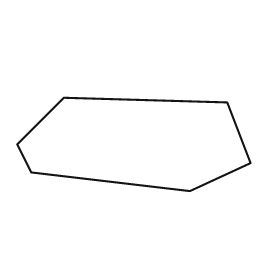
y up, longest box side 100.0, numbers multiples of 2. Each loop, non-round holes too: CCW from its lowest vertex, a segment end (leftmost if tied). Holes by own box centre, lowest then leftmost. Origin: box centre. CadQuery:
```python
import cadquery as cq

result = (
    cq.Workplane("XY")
    .moveTo(24.0, -20.0)
    .lineTo(50.0, -8.0)
    .lineTo(40.0, 18.0)
    .lineTo(-30.0, 20.0)
    .lineTo(-50.0, 0.0)
    .lineTo(-44.0, -12.0)
    .close()
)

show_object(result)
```